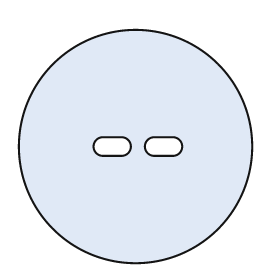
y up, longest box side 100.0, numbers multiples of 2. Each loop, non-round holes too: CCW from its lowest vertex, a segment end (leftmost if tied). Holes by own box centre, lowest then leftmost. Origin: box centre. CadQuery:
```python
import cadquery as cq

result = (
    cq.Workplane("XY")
    .moveTo(0.0, 0.0)
    .circle(50.0)
    .moveTo(-14.0, -4.0)
    .lineTo(-6.0, -4.0)
    .threePointArc((-2.0, 0.0), (-6.0, 4.0))
    .lineTo(-14.0, 4.0)
    .threePointArc((-18.0, 0.0), (-14.0, -4.0))
    .close()
    .moveTo(8.0, -4.0)
    .lineTo(16.0, -4.0)
    .threePointArc((20.0, 0.0), (16.0, 4.0))
    .lineTo(8.0, 4.0)
    .threePointArc((4.0, 0.0), (8.0, -4.0))
    .close()
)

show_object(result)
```